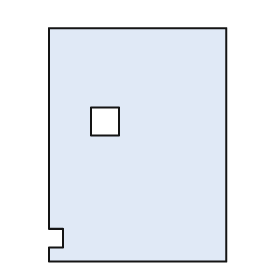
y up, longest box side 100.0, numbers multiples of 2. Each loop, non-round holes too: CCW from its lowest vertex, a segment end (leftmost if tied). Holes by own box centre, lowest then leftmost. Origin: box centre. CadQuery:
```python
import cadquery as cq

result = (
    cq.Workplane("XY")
    .moveTo(-38.0, -50.0)
    .lineTo(38.0, -50.0)
    .lineTo(38.0, 50.0)
    .lineTo(-38.0, 50.0)
    .lineTo(-38.0, -36.0)
    .lineTo(-32.0, -36.0)
    .lineTo(-32.0, -44.0)
    .lineTo(-38.0, -44.0)
    .close()
    .moveTo(-20.0, 4.0)
    .lineTo(-8.0, 4.0)
    .lineTo(-8.0, 16.0)
    .lineTo(-20.0, 16.0)
    .close()
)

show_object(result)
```